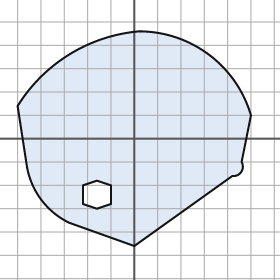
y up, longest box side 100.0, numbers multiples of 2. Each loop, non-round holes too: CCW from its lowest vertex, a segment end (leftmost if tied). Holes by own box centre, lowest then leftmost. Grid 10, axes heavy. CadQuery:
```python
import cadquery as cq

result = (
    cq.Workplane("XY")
    .moveTo(0.0, -46.0)
    .lineTo(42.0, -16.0)
    .threePointArc((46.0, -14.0), (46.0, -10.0))
    .lineTo(50.0, 10.0)
    .threePointArc((32.0, 36.0), (2.0, 46.0))
    .threePointArc((-28.0, 36.0), (-50.0, 14.0))
    .lineTo(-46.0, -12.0)
    .threePointArc((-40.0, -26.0), (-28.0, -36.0))
    .close()
    .moveTo(-16.0, -30.0)
    .lineTo(-10.0, -28.0)
    .lineTo(-10.0, -20.0)
    .lineTo(-16.0, -18.0)
    .lineTo(-22.0, -20.0)
    .lineTo(-22.0, -28.0)
    .close()
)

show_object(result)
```